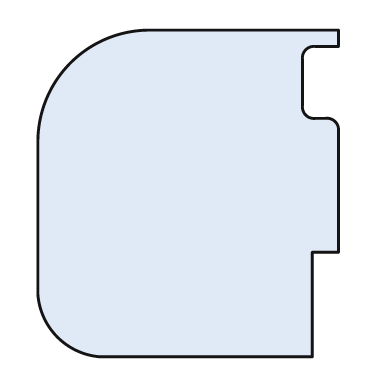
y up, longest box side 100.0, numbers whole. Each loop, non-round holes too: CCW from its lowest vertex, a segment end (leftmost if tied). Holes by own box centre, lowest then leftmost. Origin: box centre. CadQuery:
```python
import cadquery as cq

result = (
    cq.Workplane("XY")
    .moveTo(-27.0, -50.0)
    .lineTo(38.0, -50.0)
    .lineTo(38.0, -18.0)
    .lineTo(46.0, -18.0)
    .lineTo(46.0, 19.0)
    .threePointArc((45.0, 22.0), (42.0, 23.0))
    .lineTo(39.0, 23.0)
    .threePointArc((36.0, 24.0), (35.0, 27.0))
    .lineTo(35.0, 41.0)
    .threePointArc((36.0, 44.0), (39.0, 45.0))
    .lineTo(46.0, 45.0)
    .lineTo(46.0, 50.0)
    .lineTo(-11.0, 50.0)
    .threePointArc((-36.0, 40.0), (-46.0, 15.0))
    .lineTo(-46.0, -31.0)
    .threePointArc((-40.0, -44.0), (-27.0, -50.0))
    .close()
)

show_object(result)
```